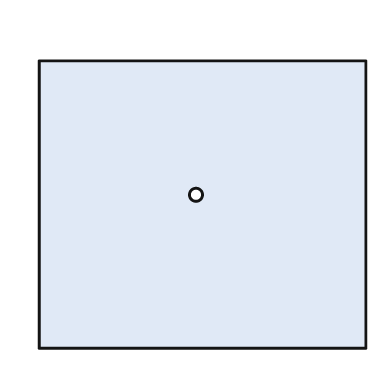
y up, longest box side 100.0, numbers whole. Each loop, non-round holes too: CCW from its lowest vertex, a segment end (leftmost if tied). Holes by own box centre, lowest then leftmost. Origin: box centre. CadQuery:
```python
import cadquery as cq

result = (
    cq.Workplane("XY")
    .moveTo(-50.0, -44.0)
    .lineTo(50.0, -44.0)
    .lineTo(50.0, 44.0)
    .lineTo(-50.0, 44.0)
    .close()
    .moveTo(-2.0, 3.0)
    .circle(2.0)
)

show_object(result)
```